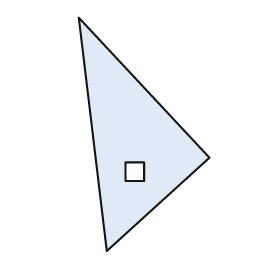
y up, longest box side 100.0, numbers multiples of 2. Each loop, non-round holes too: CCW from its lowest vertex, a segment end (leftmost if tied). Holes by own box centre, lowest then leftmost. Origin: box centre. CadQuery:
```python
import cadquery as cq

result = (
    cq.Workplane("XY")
    .moveTo(-16.0, -50.0)
    .lineTo(28.0, -10.0)
    .lineTo(-28.0, 50.0)
    .close()
    .moveTo(-8.0, -20.0)
    .lineTo(0.0, -20.0)
    .lineTo(0.0, -12.0)
    .lineTo(-8.0, -12.0)
    .close()
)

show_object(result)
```